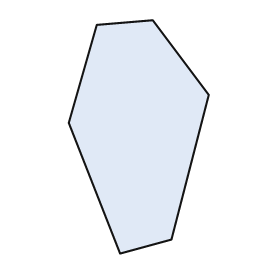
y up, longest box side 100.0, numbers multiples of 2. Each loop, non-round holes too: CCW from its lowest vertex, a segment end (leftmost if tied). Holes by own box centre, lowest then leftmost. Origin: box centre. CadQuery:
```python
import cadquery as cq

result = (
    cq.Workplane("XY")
    .moveTo(-8.0, -50.0)
    .lineTo(14.0, -44.0)
    .lineTo(30.0, 18.0)
    .lineTo(6.0, 50.0)
    .lineTo(-18.0, 48.0)
    .lineTo(-30.0, 6.0)
    .close()
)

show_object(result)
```